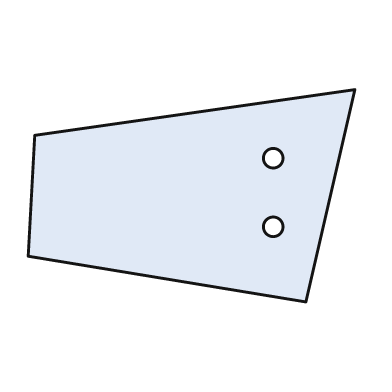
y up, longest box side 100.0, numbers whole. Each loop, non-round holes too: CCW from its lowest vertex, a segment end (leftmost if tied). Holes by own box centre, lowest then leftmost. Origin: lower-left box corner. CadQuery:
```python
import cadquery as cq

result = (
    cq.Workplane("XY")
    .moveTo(85.0, 0.0)
    .lineTo(100.0, 65.0)
    .lineTo(2.0, 51.0)
    .lineTo(0.0, 14.0)
    .close()
    .moveTo(75.0, 23.0)
    .circle(3.0)
    .moveTo(75.0, 44.0)
    .circle(3.0)
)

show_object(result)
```